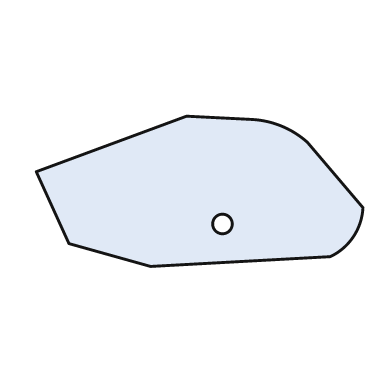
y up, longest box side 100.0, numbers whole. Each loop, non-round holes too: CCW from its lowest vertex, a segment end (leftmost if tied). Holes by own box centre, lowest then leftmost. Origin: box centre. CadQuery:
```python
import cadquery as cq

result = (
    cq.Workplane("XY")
    .moveTo(-15.0, -23.0)
    .lineTo(40.0, -20.0)
    .threePointArc((47.0, -14.0), (50.0, -5.0))
    .lineTo(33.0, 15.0)
    .threePointArc((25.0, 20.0), (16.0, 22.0))
    .lineTo(-4.0, 23.0)
    .lineTo(-50.0, 6.0)
    .lineTo(-40.0, -16.0)
    .close()
    .moveTo(7.0, -10.0)
    .circle(3.0)
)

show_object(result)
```